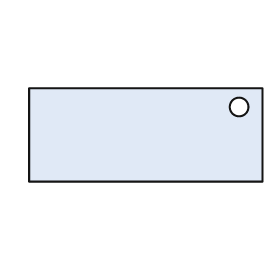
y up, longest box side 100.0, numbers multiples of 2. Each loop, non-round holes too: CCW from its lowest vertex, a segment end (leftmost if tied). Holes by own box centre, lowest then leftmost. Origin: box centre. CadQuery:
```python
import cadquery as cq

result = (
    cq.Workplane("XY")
    .moveTo(-50.0, -20.0)
    .lineTo(50.0, -20.0)
    .lineTo(50.0, 20.0)
    .lineTo(-50.0, 20.0)
    .close()
    .moveTo(40.0, 12.0)
    .circle(4.0)
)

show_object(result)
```